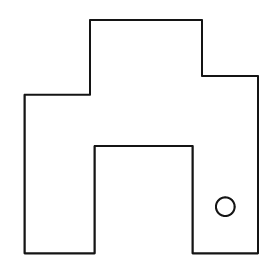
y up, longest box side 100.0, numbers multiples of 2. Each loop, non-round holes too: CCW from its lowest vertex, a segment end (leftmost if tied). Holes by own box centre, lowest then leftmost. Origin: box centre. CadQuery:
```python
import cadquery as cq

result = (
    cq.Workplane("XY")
    .moveTo(-50.0, -50.0)
    .lineTo(-20.0, -50.0)
    .lineTo(-20.0, -4.0)
    .lineTo(22.0, -4.0)
    .lineTo(22.0, -50.0)
    .lineTo(50.0, -50.0)
    .lineTo(50.0, 26.0)
    .lineTo(26.0, 26.0)
    .lineTo(26.0, 50.0)
    .lineTo(-22.0, 50.0)
    .lineTo(-22.0, 18.0)
    .lineTo(-50.0, 18.0)
    .close()
    .moveTo(36.0, -30.0)
    .circle(4.0)
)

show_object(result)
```